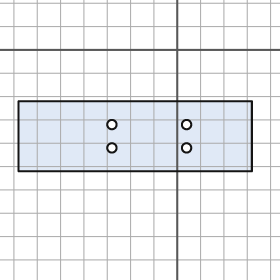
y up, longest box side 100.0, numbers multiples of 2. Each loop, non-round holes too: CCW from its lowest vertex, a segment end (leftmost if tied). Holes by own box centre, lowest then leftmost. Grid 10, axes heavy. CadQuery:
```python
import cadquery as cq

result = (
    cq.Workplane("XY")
    .moveTo(-68.0, -52.0)
    .lineTo(32.0, -52.0)
    .lineTo(32.0, -22.0)
    .lineTo(-68.0, -22.0)
    .close()
    .moveTo(-28.0, -42.0)
    .circle(2.0)
    .moveTo(4.0, -42.0)
    .circle(2.0)
    .moveTo(-28.0, -32.0)
    .circle(2.0)
    .moveTo(4.0, -32.0)
    .circle(2.0)
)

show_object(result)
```